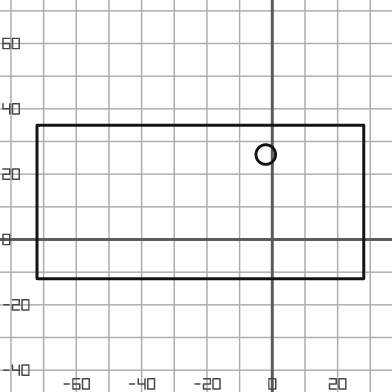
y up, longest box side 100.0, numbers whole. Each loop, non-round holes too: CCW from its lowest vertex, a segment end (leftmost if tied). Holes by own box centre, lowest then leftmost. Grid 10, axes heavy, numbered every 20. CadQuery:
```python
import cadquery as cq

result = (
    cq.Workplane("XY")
    .moveTo(-72.0, -12.0)
    .lineTo(28.0, -12.0)
    .lineTo(28.0, 35.0)
    .lineTo(-72.0, 35.0)
    .close()
    .moveTo(-2.0, 26.0)
    .circle(3.0)
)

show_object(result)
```